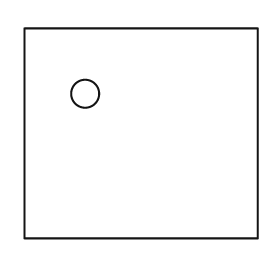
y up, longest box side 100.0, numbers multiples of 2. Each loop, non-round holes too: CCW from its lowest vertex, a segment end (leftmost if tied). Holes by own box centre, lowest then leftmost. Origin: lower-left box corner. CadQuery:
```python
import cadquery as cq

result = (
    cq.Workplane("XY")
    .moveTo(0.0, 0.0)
    .lineTo(100.0, 0.0)
    .lineTo(100.0, 90.0)
    .lineTo(0.0, 90.0)
    .close()
    .moveTo(26.0, 62.0)
    .circle(6.0)
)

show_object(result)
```